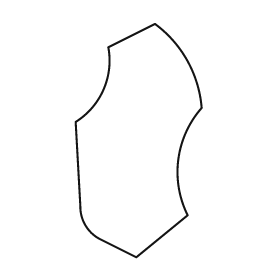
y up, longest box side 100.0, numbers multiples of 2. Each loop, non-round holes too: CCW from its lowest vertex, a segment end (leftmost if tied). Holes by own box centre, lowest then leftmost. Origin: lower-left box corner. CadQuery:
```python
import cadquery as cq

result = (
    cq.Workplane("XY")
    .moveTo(26.0, 0.0)
    .lineTo(48.0, 18.0)
    .threePointArc((44.0, 42.0), (54.0, 64.0))
    .threePointArc((48.0, 84.0), (34.0, 100.0))
    .lineTo(14.0, 90.0)
    .threePointArc((12.0, 72.0), (0.0, 58.0))
    .lineTo(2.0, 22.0)
    .threePointArc((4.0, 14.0), (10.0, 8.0))
    .close()
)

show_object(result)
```